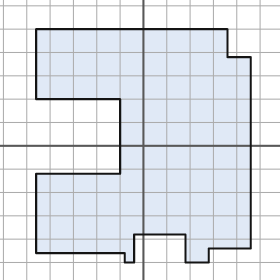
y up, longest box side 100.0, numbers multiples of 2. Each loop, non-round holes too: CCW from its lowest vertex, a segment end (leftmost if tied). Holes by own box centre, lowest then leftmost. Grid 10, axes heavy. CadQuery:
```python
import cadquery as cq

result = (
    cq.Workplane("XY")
    .moveTo(-8.0, -50.0)
    .lineTo(-4.0, -50.0)
    .lineTo(-4.0, -38.0)
    .lineTo(18.0, -38.0)
    .lineTo(18.0, -50.0)
    .lineTo(28.0, -50.0)
    .lineTo(28.0, -44.0)
    .lineTo(46.0, -44.0)
    .lineTo(46.0, 38.0)
    .lineTo(36.0, 38.0)
    .lineTo(36.0, 50.0)
    .lineTo(-46.0, 50.0)
    .lineTo(-46.0, 20.0)
    .lineTo(-10.0, 20.0)
    .lineTo(-10.0, -12.0)
    .lineTo(-46.0, -12.0)
    .lineTo(-46.0, -46.0)
    .lineTo(-8.0, -46.0)
    .close()
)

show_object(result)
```